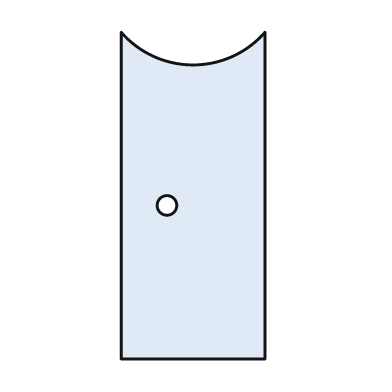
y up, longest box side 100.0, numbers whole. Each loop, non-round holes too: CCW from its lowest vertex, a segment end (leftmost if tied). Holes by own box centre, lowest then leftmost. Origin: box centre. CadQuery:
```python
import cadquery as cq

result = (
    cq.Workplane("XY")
    .moveTo(-22.0, -50.0)
    .lineTo(22.0, -50.0)
    .lineTo(22.0, 50.0)
    .threePointArc((0.0, 40.0), (-22.0, 50.0))
    .close()
    .moveTo(-8.0, -3.0)
    .circle(3.0)
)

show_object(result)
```